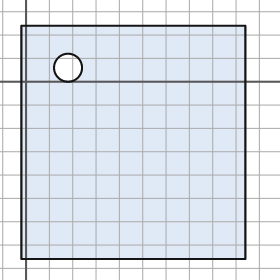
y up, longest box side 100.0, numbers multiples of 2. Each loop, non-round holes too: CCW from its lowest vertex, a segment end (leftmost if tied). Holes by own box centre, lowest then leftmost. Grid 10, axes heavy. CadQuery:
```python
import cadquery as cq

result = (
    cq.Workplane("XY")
    .moveTo(-2.0, -76.0)
    .lineTo(94.0, -76.0)
    .lineTo(94.0, 24.0)
    .lineTo(-2.0, 24.0)
    .close()
    .moveTo(18.0, 6.0)
    .circle(6.0)
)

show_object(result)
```